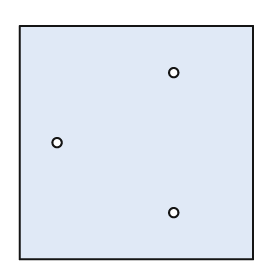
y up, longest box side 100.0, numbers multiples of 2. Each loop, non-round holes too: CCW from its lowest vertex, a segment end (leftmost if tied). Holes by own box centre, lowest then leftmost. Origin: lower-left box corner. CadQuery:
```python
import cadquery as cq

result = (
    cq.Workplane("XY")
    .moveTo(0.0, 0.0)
    .lineTo(100.0, 0.0)
    .lineTo(100.0, 100.0)
    .lineTo(0.0, 100.0)
    .close()
    .moveTo(66.0, 20.0)
    .circle(2.0)
    .moveTo(16.0, 50.0)
    .circle(2.0)
    .moveTo(66.0, 80.0)
    .circle(2.0)
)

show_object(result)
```